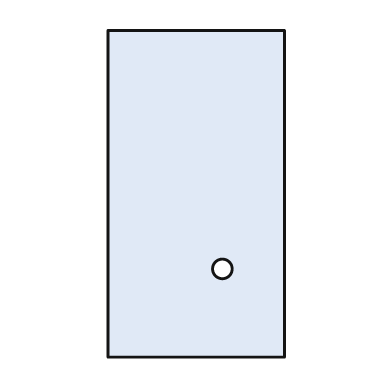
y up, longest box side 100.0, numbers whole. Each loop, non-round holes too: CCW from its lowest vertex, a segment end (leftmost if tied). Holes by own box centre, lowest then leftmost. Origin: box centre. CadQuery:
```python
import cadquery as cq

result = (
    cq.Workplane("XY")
    .moveTo(-27.0, -50.0)
    .lineTo(27.0, -50.0)
    .lineTo(27.0, 50.0)
    .lineTo(-27.0, 50.0)
    .close()
    .moveTo(8.0, -23.0)
    .circle(3.0)
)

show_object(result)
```